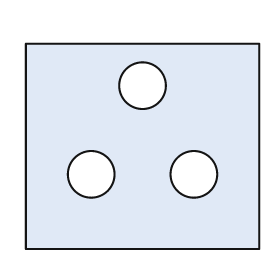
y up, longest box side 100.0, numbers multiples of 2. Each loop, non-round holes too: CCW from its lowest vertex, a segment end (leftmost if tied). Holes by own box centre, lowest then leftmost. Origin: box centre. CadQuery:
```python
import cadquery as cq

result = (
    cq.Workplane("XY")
    .moveTo(-50.0, -44.0)
    .lineTo(50.0, -44.0)
    .lineTo(50.0, 44.0)
    .lineTo(-50.0, 44.0)
    .close()
    .moveTo(-22.0, -12.0)
    .circle(10.0)
    .moveTo(22.0, -12.0)
    .circle(10.0)
    .moveTo(0.0, 26.0)
    .circle(10.0)
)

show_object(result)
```